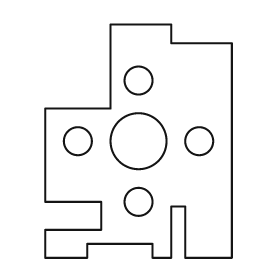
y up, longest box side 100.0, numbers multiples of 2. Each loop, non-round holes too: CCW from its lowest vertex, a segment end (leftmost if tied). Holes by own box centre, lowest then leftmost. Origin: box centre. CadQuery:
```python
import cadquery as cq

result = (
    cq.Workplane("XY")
    .moveTo(-40.0, -50.0)
    .lineTo(-22.0, -50.0)
    .lineTo(-22.0, -44.0)
    .lineTo(6.0, -44.0)
    .lineTo(6.0, -50.0)
    .lineTo(14.0, -50.0)
    .lineTo(14.0, -28.0)
    .lineTo(20.0, -28.0)
    .lineTo(20.0, -50.0)
    .lineTo(40.0, -50.0)
    .lineTo(40.0, 42.0)
    .lineTo(14.0, 42.0)
    .lineTo(14.0, 50.0)
    .lineTo(-12.0, 50.0)
    .lineTo(-12.0, 14.0)
    .lineTo(-40.0, 14.0)
    .lineTo(-40.0, -26.0)
    .lineTo(-16.0, -26.0)
    .lineTo(-16.0, -38.0)
    .lineTo(-40.0, -38.0)
    .close()
    .moveTo(0.0, -26.0)
    .circle(6.0)
    .moveTo(-26.0, 0.0)
    .circle(6.0)
    .moveTo(0.0, 0.0)
    .circle(12.0)
    .moveTo(26.0, 0.0)
    .circle(6.0)
    .moveTo(0.0, 26.0)
    .circle(6.0)
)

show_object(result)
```